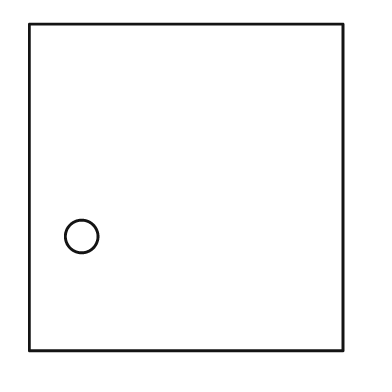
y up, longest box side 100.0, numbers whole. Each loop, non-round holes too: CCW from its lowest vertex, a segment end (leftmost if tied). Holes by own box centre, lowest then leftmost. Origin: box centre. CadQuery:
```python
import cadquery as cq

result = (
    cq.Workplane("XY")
    .moveTo(-48.0, -50.0)
    .lineTo(48.0, -50.0)
    .lineTo(48.0, 50.0)
    .lineTo(-48.0, 50.0)
    .close()
    .moveTo(-32.0, -15.0)
    .circle(5.0)
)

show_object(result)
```